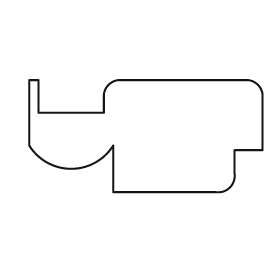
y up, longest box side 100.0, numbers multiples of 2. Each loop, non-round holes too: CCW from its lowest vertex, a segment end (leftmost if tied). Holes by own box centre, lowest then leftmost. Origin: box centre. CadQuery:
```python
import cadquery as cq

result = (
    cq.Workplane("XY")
    .moveTo(-14.0, -24.0)
    .lineTo(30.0, -24.0)
    .threePointArc((36.0, -22.0), (38.0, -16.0))
    .lineTo(38.0, -6.0)
    .lineTo(50.0, -6.0)
    .lineTo(50.0, 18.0)
    .threePointArc((48.0, 22.0), (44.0, 24.0))
    .lineTo(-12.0, 24.0)
    .threePointArc((-16.0, 22.0), (-18.0, 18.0))
    .lineTo(-18.0, 10.0)
    .lineTo(-46.0, 10.0)
    .lineTo(-46.0, 24.0)
    .lineTo(-50.0, 24.0)
    .lineTo(-50.0, -4.0)
    .threePointArc((-32.0, -14.0), (-14.0, -4.0))
    .close()
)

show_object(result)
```